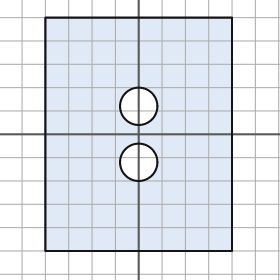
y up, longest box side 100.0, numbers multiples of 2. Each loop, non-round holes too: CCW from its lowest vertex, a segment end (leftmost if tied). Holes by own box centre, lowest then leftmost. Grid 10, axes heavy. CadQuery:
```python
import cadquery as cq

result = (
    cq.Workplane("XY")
    .moveTo(-40.0, -50.0)
    .lineTo(40.0, -50.0)
    .lineTo(40.0, 50.0)
    .lineTo(-40.0, 50.0)
    .close()
    .moveTo(0.0, -12.0)
    .circle(8.0)
    .moveTo(0.0, 12.0)
    .circle(8.0)
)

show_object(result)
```